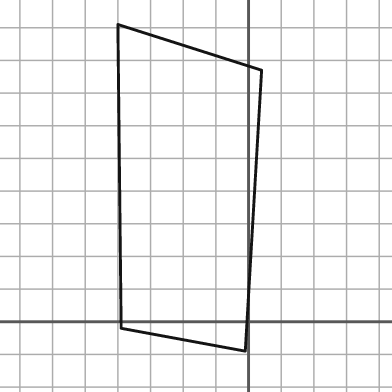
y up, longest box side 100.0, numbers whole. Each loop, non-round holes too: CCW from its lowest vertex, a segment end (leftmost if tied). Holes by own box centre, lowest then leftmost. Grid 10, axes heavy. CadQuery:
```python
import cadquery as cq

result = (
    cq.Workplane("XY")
    .moveTo(-1.0, -9.0)
    .lineTo(4.0, 77.0)
    .lineTo(-40.0, 91.0)
    .lineTo(-39.0, -2.0)
    .close()
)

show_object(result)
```